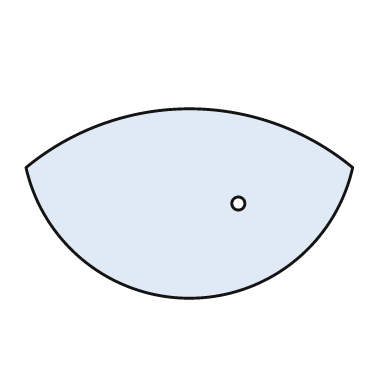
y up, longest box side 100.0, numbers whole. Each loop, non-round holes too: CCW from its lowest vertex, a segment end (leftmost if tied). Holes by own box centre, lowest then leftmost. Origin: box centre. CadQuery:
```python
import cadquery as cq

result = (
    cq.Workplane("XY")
    .moveTo(-50.0, 11.0)
    .threePointArc((0.0, -29.0), (50.0, 11.0))
    .threePointArc((0.0, 29.0), (-50.0, 11.0))
    .close()
    .moveTo(15.0, 0.0)
    .circle(2.0)
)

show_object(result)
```